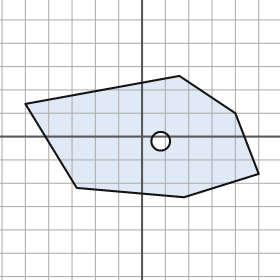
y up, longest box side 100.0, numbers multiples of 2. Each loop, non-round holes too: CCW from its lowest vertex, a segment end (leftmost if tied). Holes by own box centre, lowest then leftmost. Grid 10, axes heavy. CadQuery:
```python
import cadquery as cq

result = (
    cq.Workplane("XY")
    .moveTo(18.0, -26.0)
    .lineTo(50.0, -16.0)
    .lineTo(40.0, 10.0)
    .lineTo(16.0, 26.0)
    .lineTo(-50.0, 14.0)
    .lineTo(-28.0, -22.0)
    .close()
    .moveTo(8.0, -2.0)
    .circle(4.0)
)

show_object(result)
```